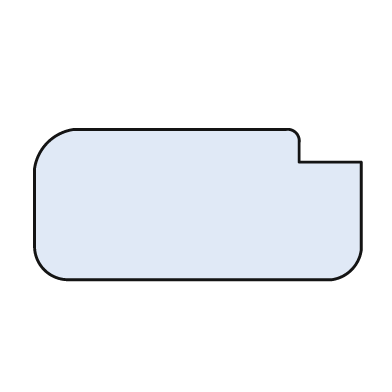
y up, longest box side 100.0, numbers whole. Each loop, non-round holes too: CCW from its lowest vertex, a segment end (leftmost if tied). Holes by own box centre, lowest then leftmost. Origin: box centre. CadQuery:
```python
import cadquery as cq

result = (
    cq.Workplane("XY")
    .moveTo(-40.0, -23.0)
    .lineTo(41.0, -23.0)
    .threePointArc((47.0, -20.0), (50.0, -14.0))
    .lineTo(50.0, 13.0)
    .lineTo(31.0, 13.0)
    .lineTo(31.0, 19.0)
    .threePointArc((30.0, 22.0), (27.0, 23.0))
    .lineTo(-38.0, 23.0)
    .threePointArc((-46.0, 19.0), (-50.0, 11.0))
    .lineTo(-50.0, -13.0)
    .threePointArc((-47.0, -20.0), (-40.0, -23.0))
    .close()
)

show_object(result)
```